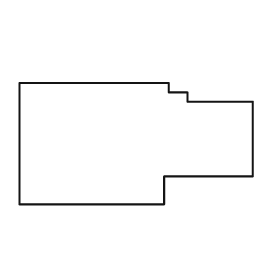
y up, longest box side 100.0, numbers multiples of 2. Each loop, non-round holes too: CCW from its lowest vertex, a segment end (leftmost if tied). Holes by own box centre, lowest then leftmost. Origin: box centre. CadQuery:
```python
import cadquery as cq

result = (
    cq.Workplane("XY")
    .moveTo(-50.0, -26.0)
    .lineTo(12.0, -26.0)
    .lineTo(12.0, -14.0)
    .lineTo(50.0, -14.0)
    .lineTo(50.0, 18.0)
    .lineTo(22.0, 18.0)
    .lineTo(22.0, 22.0)
    .lineTo(14.0, 22.0)
    .lineTo(14.0, 26.0)
    .lineTo(-50.0, 26.0)
    .close()
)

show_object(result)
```